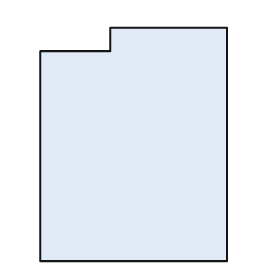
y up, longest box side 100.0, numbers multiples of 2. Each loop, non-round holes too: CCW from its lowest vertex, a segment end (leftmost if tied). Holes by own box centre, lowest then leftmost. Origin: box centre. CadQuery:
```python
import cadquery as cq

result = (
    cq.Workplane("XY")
    .moveTo(-40.0, -50.0)
    .lineTo(40.0, -50.0)
    .lineTo(40.0, 50.0)
    .lineTo(-10.0, 50.0)
    .lineTo(-10.0, 40.0)
    .lineTo(-40.0, 40.0)
    .close()
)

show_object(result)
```